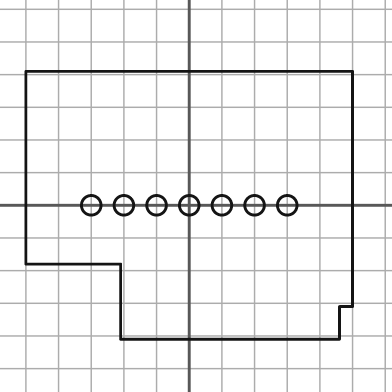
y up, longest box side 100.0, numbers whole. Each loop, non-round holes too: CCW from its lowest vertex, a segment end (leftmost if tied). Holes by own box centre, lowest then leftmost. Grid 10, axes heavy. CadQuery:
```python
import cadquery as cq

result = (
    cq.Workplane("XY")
    .moveTo(-21.0, -41.0)
    .lineTo(46.0, -41.0)
    .lineTo(46.0, -31.0)
    .lineTo(50.0, -31.0)
    .lineTo(50.0, 41.0)
    .lineTo(-50.0, 41.0)
    .lineTo(-50.0, -18.0)
    .lineTo(-21.0, -18.0)
    .close()
    .moveTo(-30.0, 0.0)
    .circle(3.0)
    .moveTo(-20.0, 0.0)
    .circle(3.0)
    .moveTo(-10.0, 0.0)
    .circle(3.0)
    .moveTo(0.0, 0.0)
    .circle(3.0)
    .moveTo(10.0, 0.0)
    .circle(3.0)
    .moveTo(20.0, 0.0)
    .circle(3.0)
    .moveTo(30.0, 0.0)
    .circle(3.0)
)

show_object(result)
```